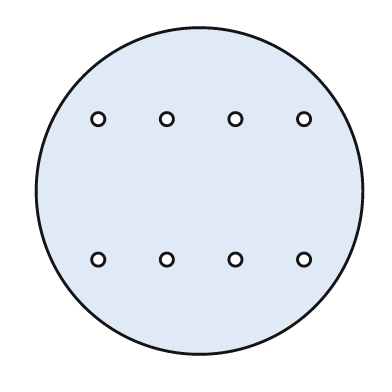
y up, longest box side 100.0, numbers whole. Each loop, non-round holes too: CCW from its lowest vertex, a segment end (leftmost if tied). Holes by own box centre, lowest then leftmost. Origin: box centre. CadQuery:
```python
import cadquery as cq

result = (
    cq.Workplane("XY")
    .moveTo(0.0, 0.0)
    .circle(50.0)
    .moveTo(-31.0, -21.0)
    .circle(2.0)
    .moveTo(-10.0, -21.0)
    .circle(2.0)
    .moveTo(11.0, -21.0)
    .circle(2.0)
    .moveTo(32.0, -21.0)
    .circle(2.0)
    .moveTo(-31.0, 22.0)
    .circle(2.0)
    .moveTo(-10.0, 22.0)
    .circle(2.0)
    .moveTo(11.0, 22.0)
    .circle(2.0)
    .moveTo(32.0, 22.0)
    .circle(2.0)
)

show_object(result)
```